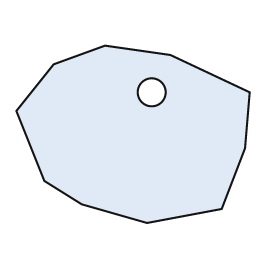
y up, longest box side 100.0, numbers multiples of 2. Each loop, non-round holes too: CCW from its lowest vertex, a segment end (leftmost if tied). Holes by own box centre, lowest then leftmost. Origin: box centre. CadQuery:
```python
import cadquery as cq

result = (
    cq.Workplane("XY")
    .moveTo(6.0, -38.0)
    .lineTo(38.0, -32.0)
    .lineTo(48.0, -6.0)
    .lineTo(50.0, 18.0)
    .lineTo(16.0, 34.0)
    .lineTo(-12.0, 38.0)
    .lineTo(-34.0, 30.0)
    .lineTo(-50.0, 10.0)
    .lineTo(-38.0, -20.0)
    .lineTo(-22.0, -30.0)
    .close()
    .moveTo(8.0, 18.0)
    .circle(6.0)
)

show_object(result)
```